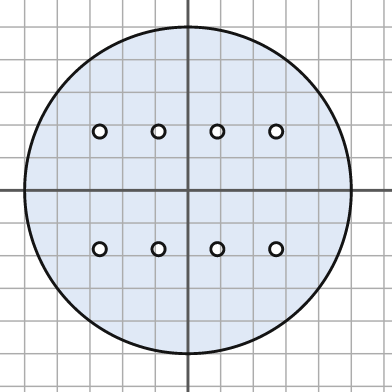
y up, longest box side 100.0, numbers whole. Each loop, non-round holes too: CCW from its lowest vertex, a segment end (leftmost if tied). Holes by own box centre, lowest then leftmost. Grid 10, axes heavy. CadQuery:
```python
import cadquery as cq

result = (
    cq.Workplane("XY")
    .moveTo(0.0, 0.0)
    .circle(50.0)
    .moveTo(-27.0, -18.0)
    .circle(2.0)
    .moveTo(-9.0, -18.0)
    .circle(2.0)
    .moveTo(9.0, -18.0)
    .circle(2.0)
    .moveTo(27.0, -18.0)
    .circle(2.0)
    .moveTo(-27.0, 18.0)
    .circle(2.0)
    .moveTo(-9.0, 18.0)
    .circle(2.0)
    .moveTo(9.0, 18.0)
    .circle(2.0)
    .moveTo(27.0, 18.0)
    .circle(2.0)
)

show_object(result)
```